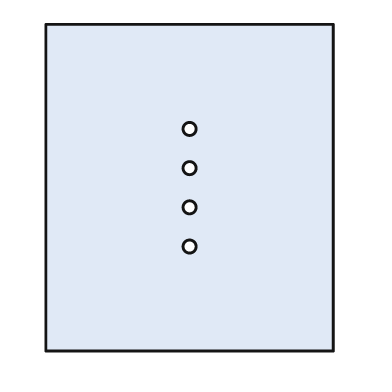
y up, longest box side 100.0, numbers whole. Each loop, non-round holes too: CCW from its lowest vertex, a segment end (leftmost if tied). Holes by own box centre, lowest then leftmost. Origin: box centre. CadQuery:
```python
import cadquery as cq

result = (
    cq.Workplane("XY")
    .moveTo(-44.0, -50.0)
    .lineTo(44.0, -50.0)
    .lineTo(44.0, 50.0)
    .lineTo(-44.0, 50.0)
    .close()
    .moveTo(0.0, -18.0)
    .circle(2.0)
    .moveTo(0.0, -6.0)
    .circle(2.0)
    .moveTo(0.0, 6.0)
    .circle(2.0)
    .moveTo(0.0, 18.0)
    .circle(2.0)
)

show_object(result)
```